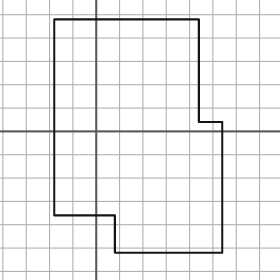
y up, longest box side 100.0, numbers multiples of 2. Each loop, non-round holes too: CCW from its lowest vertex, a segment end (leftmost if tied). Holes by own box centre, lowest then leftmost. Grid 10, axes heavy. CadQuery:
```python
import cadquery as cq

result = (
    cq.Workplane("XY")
    .moveTo(8.0, -52.0)
    .lineTo(54.0, -52.0)
    .lineTo(54.0, 4.0)
    .lineTo(44.0, 4.0)
    .lineTo(44.0, 48.0)
    .lineTo(-18.0, 48.0)
    .lineTo(-18.0, -36.0)
    .lineTo(8.0, -36.0)
    .close()
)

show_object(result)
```